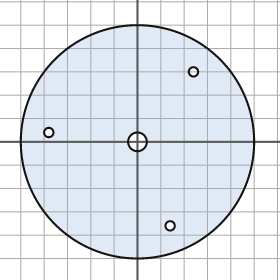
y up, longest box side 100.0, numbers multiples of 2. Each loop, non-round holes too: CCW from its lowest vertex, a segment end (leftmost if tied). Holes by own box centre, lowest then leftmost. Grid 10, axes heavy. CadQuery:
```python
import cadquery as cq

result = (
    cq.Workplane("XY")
    .moveTo(0.0, 0.0)
    .circle(50.0)
    .moveTo(14.0, -36.0)
    .circle(2.0)
    .moveTo(0.0, 0.0)
    .circle(4.0)
    .moveTo(-38.0, 4.0)
    .circle(2.0)
    .moveTo(24.0, 30.0)
    .circle(2.0)
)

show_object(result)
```